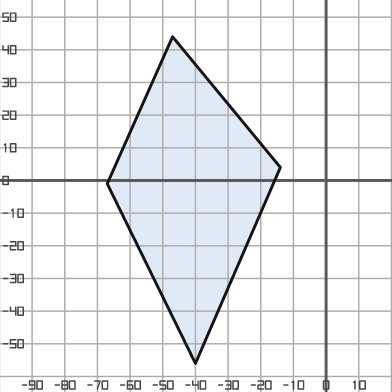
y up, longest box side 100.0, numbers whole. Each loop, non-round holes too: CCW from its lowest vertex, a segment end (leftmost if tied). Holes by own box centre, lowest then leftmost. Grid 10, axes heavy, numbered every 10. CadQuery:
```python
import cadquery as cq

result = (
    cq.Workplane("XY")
    .moveTo(-40.0, -56.0)
    .lineTo(-14.0, 4.0)
    .lineTo(-47.0, 44.0)
    .lineTo(-67.0, -1.0)
    .close()
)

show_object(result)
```